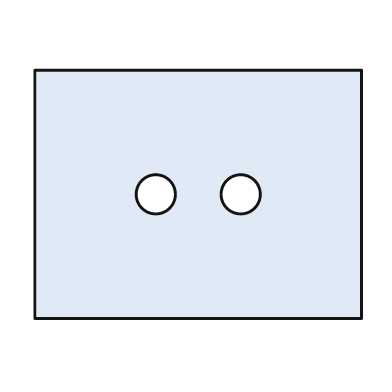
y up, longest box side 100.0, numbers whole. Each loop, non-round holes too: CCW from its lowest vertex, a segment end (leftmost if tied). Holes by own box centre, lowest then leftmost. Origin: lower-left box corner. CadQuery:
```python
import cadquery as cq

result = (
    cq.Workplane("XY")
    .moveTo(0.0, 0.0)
    .lineTo(100.0, 0.0)
    .lineTo(100.0, 76.0)
    .lineTo(0.0, 76.0)
    .close()
    .moveTo(37.0, 38.0)
    .circle(6.0)
    .moveTo(63.0, 38.0)
    .circle(6.0)
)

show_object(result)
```